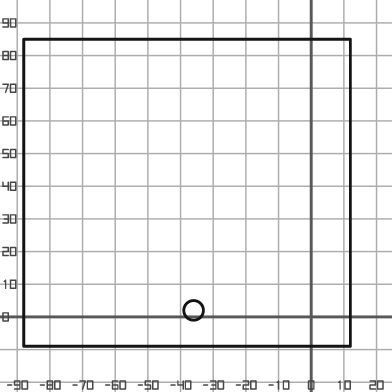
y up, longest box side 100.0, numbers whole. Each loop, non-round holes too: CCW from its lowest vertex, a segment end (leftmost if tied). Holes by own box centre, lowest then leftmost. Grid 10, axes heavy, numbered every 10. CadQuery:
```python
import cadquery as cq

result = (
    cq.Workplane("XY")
    .moveTo(-88.0, -9.0)
    .lineTo(12.0, -9.0)
    .lineTo(12.0, 85.0)
    .lineTo(-88.0, 85.0)
    .close()
    .moveTo(-36.0, 2.0)
    .circle(3.0)
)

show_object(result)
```